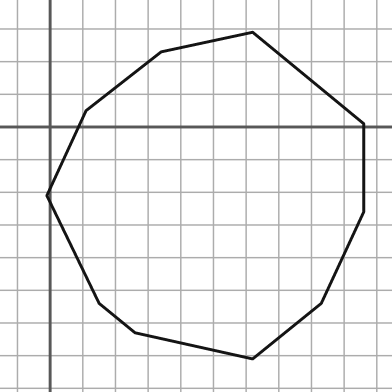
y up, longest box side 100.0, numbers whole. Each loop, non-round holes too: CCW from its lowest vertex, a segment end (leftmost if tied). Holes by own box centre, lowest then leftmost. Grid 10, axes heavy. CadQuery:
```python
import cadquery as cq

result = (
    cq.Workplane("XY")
    .moveTo(62.0, -71.0)
    .lineTo(83.0, -54.0)
    .lineTo(96.0, -26.0)
    .lineTo(96.0, 1.0)
    .lineTo(62.0, 29.0)
    .lineTo(34.0, 23.0)
    .lineTo(11.0, 5.0)
    .lineTo(-1.0, -21.0)
    .lineTo(15.0, -54.0)
    .lineTo(26.0, -63.0)
    .close()
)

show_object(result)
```